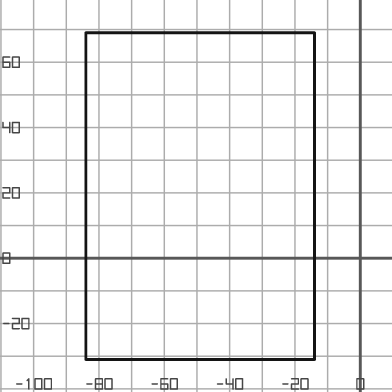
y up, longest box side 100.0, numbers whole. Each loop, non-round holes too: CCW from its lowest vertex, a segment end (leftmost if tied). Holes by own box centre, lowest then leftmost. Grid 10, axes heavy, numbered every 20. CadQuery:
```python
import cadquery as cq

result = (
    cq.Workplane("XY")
    .moveTo(-84.0, -31.0)
    .lineTo(-14.0, -31.0)
    .lineTo(-14.0, 69.0)
    .lineTo(-84.0, 69.0)
    .close()
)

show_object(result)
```